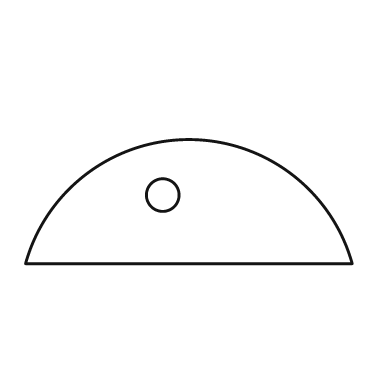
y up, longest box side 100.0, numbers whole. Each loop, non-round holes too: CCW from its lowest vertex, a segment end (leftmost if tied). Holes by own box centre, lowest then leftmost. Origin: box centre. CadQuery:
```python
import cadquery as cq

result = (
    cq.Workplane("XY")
    .moveTo(-50.0, -19.0)
    .lineTo(50.0, -19.0)
    .threePointArc((0.0, 19.0), (-50.0, -19.0))
    .close()
    .moveTo(-8.0, 2.0)
    .circle(5.0)
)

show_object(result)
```